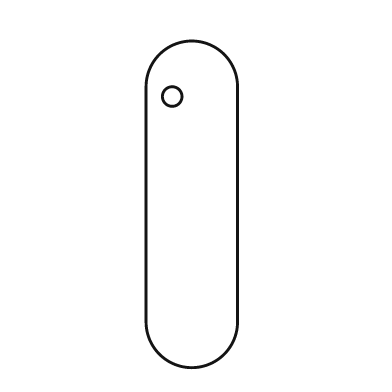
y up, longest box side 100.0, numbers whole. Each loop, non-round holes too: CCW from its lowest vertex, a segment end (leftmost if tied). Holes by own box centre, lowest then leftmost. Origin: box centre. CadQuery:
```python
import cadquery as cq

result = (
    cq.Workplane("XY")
    .moveTo(-14.0, -36.0)
    .threePointArc((0.0, -50.0), (14.0, -36.0))
    .lineTo(14.0, 36.0)
    .threePointArc((0.0, 50.0), (-14.0, 36.0))
    .close()
    .moveTo(-6.0, 33.0)
    .circle(3.0)
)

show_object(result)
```